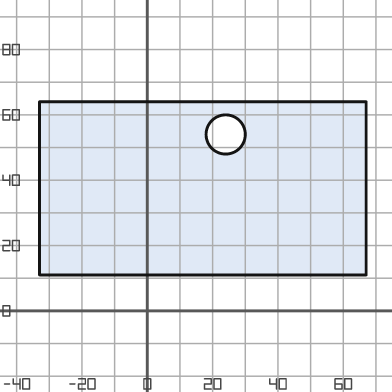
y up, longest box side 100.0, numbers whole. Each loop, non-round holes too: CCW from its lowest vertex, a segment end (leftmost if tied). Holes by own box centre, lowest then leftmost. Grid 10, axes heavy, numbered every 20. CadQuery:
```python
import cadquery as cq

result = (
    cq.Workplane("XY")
    .moveTo(-33.0, 11.0)
    .lineTo(67.0, 11.0)
    .lineTo(67.0, 64.0)
    .lineTo(-33.0, 64.0)
    .close()
    .moveTo(24.0, 54.0)
    .circle(6.0)
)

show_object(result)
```